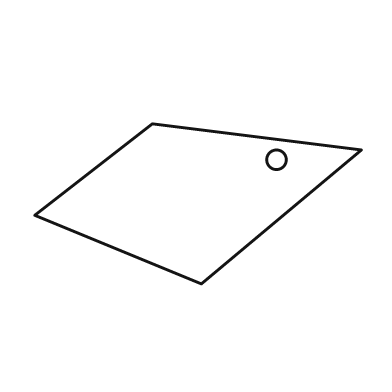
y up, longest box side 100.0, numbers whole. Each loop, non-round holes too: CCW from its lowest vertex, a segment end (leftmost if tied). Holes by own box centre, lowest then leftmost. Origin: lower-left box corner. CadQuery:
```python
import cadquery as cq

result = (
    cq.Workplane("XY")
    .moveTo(51.0, 0.0)
    .lineTo(100.0, 41.0)
    .lineTo(36.0, 49.0)
    .lineTo(0.0, 21.0)
    .close()
    .moveTo(74.0, 38.0)
    .circle(3.0)
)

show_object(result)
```